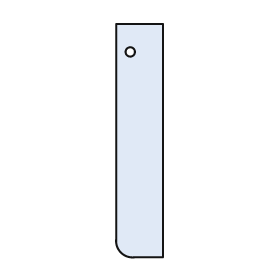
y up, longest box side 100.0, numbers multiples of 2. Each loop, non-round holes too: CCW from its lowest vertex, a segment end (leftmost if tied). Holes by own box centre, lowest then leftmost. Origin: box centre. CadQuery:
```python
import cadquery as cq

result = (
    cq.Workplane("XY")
    .moveTo(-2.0, -50.0)
    .lineTo(10.0, -50.0)
    .lineTo(10.0, 50.0)
    .lineTo(-10.0, 50.0)
    .lineTo(-10.0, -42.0)
    .threePointArc((-8.0, -48.0), (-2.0, -50.0))
    .close()
    .moveTo(-4.0, 38.0)
    .circle(2.0)
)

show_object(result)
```